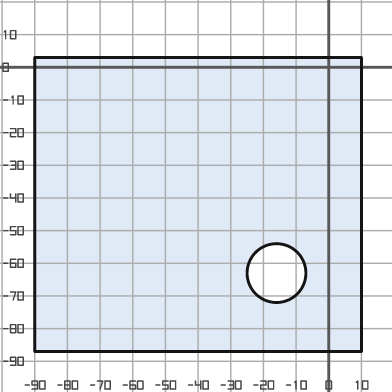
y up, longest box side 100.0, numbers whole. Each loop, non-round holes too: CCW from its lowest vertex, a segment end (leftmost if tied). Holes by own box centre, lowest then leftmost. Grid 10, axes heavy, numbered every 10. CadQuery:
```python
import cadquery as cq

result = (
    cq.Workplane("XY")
    .moveTo(-90.0, -87.0)
    .lineTo(10.0, -87.0)
    .lineTo(10.0, 3.0)
    .lineTo(-90.0, 3.0)
    .close()
    .moveTo(-16.0, -63.0)
    .circle(9.0)
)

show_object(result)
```